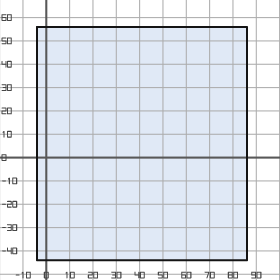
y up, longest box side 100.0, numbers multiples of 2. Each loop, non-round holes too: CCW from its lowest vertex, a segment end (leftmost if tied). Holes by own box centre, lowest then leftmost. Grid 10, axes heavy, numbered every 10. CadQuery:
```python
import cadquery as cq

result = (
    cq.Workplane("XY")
    .moveTo(-4.0, -44.0)
    .lineTo(86.0, -44.0)
    .lineTo(86.0, 56.0)
    .lineTo(-4.0, 56.0)
    .close()
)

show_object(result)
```